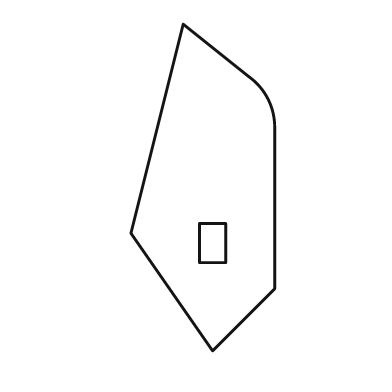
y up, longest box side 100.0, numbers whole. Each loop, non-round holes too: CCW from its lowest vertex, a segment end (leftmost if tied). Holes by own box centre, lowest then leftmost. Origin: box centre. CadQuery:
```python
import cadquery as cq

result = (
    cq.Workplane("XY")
    .moveTo(3.0, -50.0)
    .lineTo(22.0, -31.0)
    .lineTo(22.0, 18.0)
    .threePointArc((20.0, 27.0), (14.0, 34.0))
    .lineTo(-6.0, 50.0)
    .lineTo(-22.0, -14.0)
    .close()
    .moveTo(-1.0, -23.0)
    .lineTo(7.0, -23.0)
    .lineTo(7.0, -11.0)
    .lineTo(-1.0, -11.0)
    .close()
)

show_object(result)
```